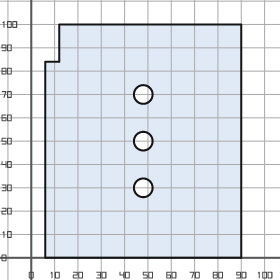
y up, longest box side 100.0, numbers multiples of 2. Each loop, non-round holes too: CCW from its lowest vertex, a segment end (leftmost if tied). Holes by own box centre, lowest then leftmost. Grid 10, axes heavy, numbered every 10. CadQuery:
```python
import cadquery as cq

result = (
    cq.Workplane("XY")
    .moveTo(6.0, 0.0)
    .lineTo(90.0, 0.0)
    .lineTo(90.0, 100.0)
    .lineTo(12.0, 100.0)
    .lineTo(12.0, 84.0)
    .lineTo(6.0, 84.0)
    .close()
    .moveTo(48.0, 30.0)
    .circle(4.0)
    .moveTo(48.0, 50.0)
    .circle(4.0)
    .moveTo(48.0, 70.0)
    .circle(4.0)
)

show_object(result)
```